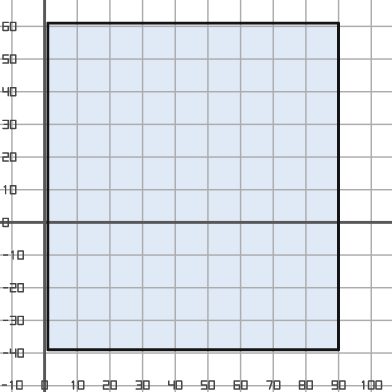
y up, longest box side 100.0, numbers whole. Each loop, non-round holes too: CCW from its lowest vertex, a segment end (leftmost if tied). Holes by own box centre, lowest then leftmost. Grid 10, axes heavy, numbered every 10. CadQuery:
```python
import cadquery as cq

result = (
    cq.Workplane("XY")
    .moveTo(1.0, -39.0)
    .lineTo(90.0, -39.0)
    .lineTo(90.0, 61.0)
    .lineTo(1.0, 61.0)
    .close()
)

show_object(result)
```